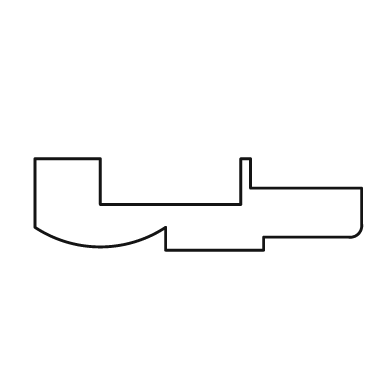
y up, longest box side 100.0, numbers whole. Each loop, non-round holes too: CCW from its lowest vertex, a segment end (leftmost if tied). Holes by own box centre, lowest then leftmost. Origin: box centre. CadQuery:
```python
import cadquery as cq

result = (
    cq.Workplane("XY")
    .moveTo(-10.0, -14.0)
    .lineTo(20.0, -14.0)
    .lineTo(20.0, -10.0)
    .lineTo(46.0, -10.0)
    .threePointArc((49.0, -9.0), (50.0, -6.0))
    .lineTo(50.0, 5.0)
    .lineTo(16.0, 5.0)
    .lineTo(16.0, 14.0)
    .lineTo(13.0, 14.0)
    .lineTo(13.0, 0.0)
    .lineTo(-30.0, 0.0)
    .lineTo(-30.0, 14.0)
    .lineTo(-50.0, 14.0)
    .lineTo(-50.0, -7.0)
    .threePointArc((-30.0, -13.0), (-10.0, -7.0))
    .close()
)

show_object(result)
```